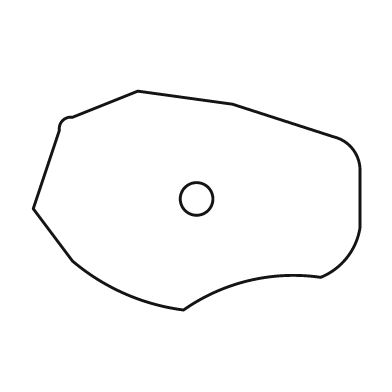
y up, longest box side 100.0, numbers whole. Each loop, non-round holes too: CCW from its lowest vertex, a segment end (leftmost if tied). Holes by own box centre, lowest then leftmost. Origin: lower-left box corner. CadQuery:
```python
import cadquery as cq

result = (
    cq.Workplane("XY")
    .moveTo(46.0, 0.0)
    .threePointArc((66.0, 9.0), (88.0, 10.0))
    .threePointArc((96.0, 16.0), (100.0, 25.0))
    .lineTo(100.0, 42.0)
    .threePointArc((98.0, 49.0), (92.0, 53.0))
    .lineTo(61.0, 63.0)
    .lineTo(32.0, 67.0)
    .lineTo(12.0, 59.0)
    .threePointArc((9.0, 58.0), (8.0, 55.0))
    .lineTo(0.0, 31.0)
    .lineTo(12.0, 15.0)
    .threePointArc((28.0, 5.0), (46.0, 0.0))
    .close()
    .moveTo(50.0, 34.0)
    .circle(5.0)
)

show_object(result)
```